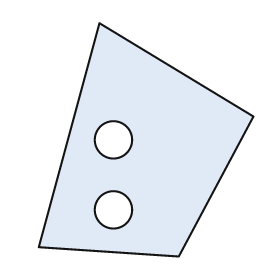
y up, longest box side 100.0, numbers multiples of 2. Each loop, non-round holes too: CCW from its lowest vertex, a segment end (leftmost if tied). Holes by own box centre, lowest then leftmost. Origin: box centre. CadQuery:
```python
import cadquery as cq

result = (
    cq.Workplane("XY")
    .moveTo(14.0, -50.0)
    .lineTo(46.0, 10.0)
    .lineTo(-20.0, 50.0)
    .lineTo(-46.0, -46.0)
    .close()
    .moveTo(-14.0, -30.0)
    .circle(8.0)
    .moveTo(-14.0, 0.0)
    .circle(8.0)
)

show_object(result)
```